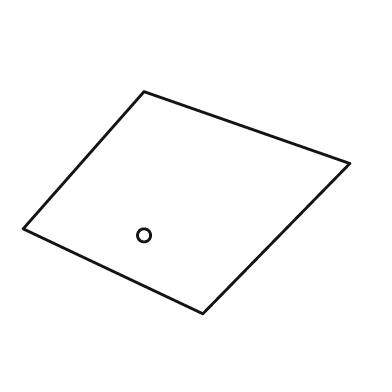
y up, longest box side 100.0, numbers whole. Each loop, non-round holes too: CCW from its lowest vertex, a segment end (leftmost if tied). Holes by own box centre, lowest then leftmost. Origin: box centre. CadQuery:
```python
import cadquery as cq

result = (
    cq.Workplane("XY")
    .moveTo(5.0, -34.0)
    .lineTo(50.0, 12.0)
    .lineTo(-13.0, 34.0)
    .lineTo(-50.0, -8.0)
    .close()
    .moveTo(-13.0, -10.0)
    .circle(2.0)
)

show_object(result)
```